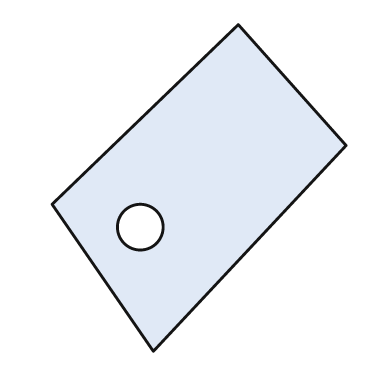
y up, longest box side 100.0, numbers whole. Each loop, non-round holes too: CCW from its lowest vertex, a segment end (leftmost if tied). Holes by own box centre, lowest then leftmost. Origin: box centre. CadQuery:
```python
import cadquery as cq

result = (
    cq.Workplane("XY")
    .moveTo(-14.0, -50.0)
    .lineTo(45.0, 13.0)
    .lineTo(12.0, 50.0)
    .lineTo(-45.0, -5.0)
    .close()
    .moveTo(-18.0, -12.0)
    .circle(7.0)
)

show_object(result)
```